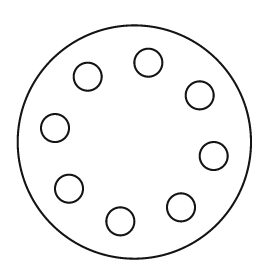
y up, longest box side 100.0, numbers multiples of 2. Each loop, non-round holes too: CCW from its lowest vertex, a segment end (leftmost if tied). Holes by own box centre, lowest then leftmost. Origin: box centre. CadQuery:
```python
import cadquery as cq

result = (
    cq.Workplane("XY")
    .moveTo(0.0, 0.0)
    .circle(50.0)
    .moveTo(-6.0, -34.0)
    .circle(6.0)
    .moveTo(20.0, -28.0)
    .circle(6.0)
    .moveTo(-28.0, -20.0)
    .circle(6.0)
    .moveTo(34.0, -6.0)
    .circle(6.0)
    .moveTo(-34.0, 6.0)
    .circle(6.0)
    .moveTo(28.0, 20.0)
    .circle(6.0)
    .moveTo(-20.0, 28.0)
    .circle(6.0)
    .moveTo(6.0, 34.0)
    .circle(6.0)
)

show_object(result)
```